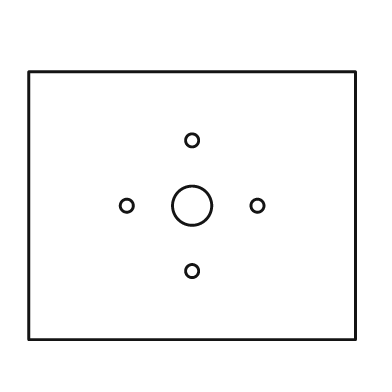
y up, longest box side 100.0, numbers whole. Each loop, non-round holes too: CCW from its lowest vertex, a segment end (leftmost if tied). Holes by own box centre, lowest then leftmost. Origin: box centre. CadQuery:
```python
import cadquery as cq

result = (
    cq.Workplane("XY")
    .moveTo(-50.0, -41.0)
    .lineTo(50.0, -41.0)
    .lineTo(50.0, 41.0)
    .lineTo(-50.0, 41.0)
    .close()
    .moveTo(0.0, -20.0)
    .circle(2.0)
    .moveTo(-20.0, 0.0)
    .circle(2.0)
    .moveTo(0.0, 0.0)
    .circle(6.0)
    .moveTo(20.0, 0.0)
    .circle(2.0)
    .moveTo(0.0, 20.0)
    .circle(2.0)
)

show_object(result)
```